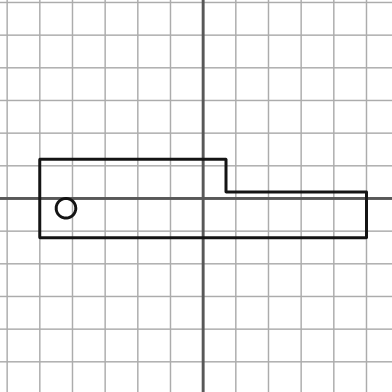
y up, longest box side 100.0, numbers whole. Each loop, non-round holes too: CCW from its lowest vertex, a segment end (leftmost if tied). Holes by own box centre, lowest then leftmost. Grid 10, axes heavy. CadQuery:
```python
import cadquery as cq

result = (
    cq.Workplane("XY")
    .moveTo(-50.0, -12.0)
    .lineTo(50.0, -12.0)
    .lineTo(50.0, 2.0)
    .lineTo(7.0, 2.0)
    .lineTo(7.0, 12.0)
    .lineTo(-50.0, 12.0)
    .close()
    .moveTo(-42.0, -3.0)
    .circle(3.0)
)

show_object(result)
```